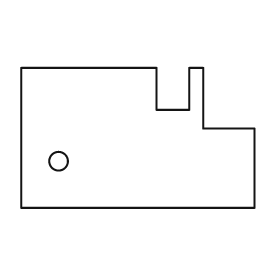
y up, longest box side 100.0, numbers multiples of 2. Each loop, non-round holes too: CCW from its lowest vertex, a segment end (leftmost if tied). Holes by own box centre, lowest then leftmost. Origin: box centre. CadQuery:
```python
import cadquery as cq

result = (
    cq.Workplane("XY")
    .moveTo(-50.0, -30.0)
    .lineTo(50.0, -30.0)
    .lineTo(50.0, 4.0)
    .lineTo(28.0, 4.0)
    .lineTo(28.0, 30.0)
    .lineTo(22.0, 30.0)
    .lineTo(22.0, 12.0)
    .lineTo(8.0, 12.0)
    .lineTo(8.0, 30.0)
    .lineTo(-50.0, 30.0)
    .close()
    .moveTo(-34.0, -10.0)
    .circle(4.0)
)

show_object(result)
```